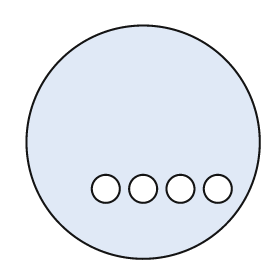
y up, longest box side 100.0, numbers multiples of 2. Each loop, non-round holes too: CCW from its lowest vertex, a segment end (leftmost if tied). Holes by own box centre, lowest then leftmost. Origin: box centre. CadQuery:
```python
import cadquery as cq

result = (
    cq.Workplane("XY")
    .moveTo(0.0, 0.0)
    .circle(50.0)
    .moveTo(-16.0, -20.0)
    .circle(6.0)
    .moveTo(0.0, -20.0)
    .circle(6.0)
    .moveTo(16.0, -20.0)
    .circle(6.0)
    .moveTo(32.0, -20.0)
    .circle(6.0)
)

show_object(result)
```